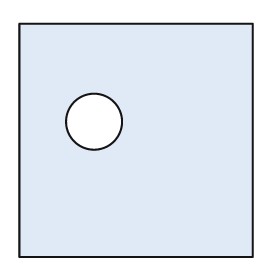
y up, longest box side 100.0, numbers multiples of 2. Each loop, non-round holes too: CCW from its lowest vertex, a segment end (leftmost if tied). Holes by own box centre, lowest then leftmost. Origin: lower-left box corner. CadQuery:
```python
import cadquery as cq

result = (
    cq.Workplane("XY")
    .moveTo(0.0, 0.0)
    .lineTo(100.0, 0.0)
    .lineTo(100.0, 100.0)
    .lineTo(0.0, 100.0)
    .close()
    .moveTo(32.0, 58.0)
    .circle(12.0)
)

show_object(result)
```